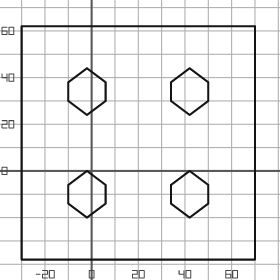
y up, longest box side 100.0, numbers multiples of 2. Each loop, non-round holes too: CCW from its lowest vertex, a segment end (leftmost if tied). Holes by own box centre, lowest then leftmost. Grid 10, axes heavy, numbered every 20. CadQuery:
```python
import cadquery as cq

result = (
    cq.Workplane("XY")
    .moveTo(-30.0, -38.0)
    .lineTo(70.0, -38.0)
    .lineTo(70.0, 62.0)
    .lineTo(-30.0, 62.0)
    .close()
    .moveTo(-2.0, -20.0)
    .lineTo(6.0, -14.0)
    .lineTo(6.0, -6.0)
    .lineTo(-2.0, 0.0)
    .lineTo(-10.0, -6.0)
    .lineTo(-10.0, -14.0)
    .close()
    .moveTo(42.0, -20.0)
    .lineTo(50.0, -14.0)
    .lineTo(50.0, -6.0)
    .lineTo(42.0, 0.0)
    .lineTo(34.0, -6.0)
    .lineTo(34.0, -14.0)
    .close()
    .moveTo(-2.0, 24.0)
    .lineTo(6.0, 30.0)
    .lineTo(6.0, 38.0)
    .lineTo(-2.0, 44.0)
    .lineTo(-10.0, 38.0)
    .lineTo(-10.0, 30.0)
    .close()
    .moveTo(42.0, 24.0)
    .lineTo(50.0, 30.0)
    .lineTo(50.0, 38.0)
    .lineTo(42.0, 44.0)
    .lineTo(34.0, 38.0)
    .lineTo(34.0, 30.0)
    .close()
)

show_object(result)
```